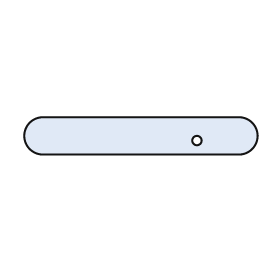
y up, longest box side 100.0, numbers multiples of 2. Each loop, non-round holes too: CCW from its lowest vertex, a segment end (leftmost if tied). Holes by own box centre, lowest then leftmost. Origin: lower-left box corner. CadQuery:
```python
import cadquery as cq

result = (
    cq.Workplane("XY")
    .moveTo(8.0, 0.0)
    .lineTo(92.0, 0.0)
    .threePointArc((100.0, 8.0), (92.0, 16.0))
    .lineTo(8.0, 16.0)
    .threePointArc((0.0, 8.0), (8.0, 0.0))
    .close()
    .moveTo(74.0, 6.0)
    .circle(2.0)
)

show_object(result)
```